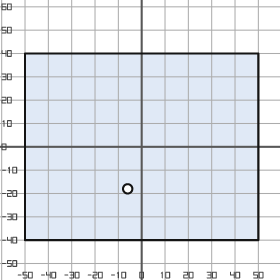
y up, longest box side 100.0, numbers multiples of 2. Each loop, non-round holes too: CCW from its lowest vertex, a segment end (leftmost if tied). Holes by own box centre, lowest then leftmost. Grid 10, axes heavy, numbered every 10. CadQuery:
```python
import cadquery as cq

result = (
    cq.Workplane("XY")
    .moveTo(-50.0, -40.0)
    .lineTo(50.0, -40.0)
    .lineTo(50.0, 40.0)
    .lineTo(-50.0, 40.0)
    .close()
    .moveTo(-6.0, -18.0)
    .circle(2.0)
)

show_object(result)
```